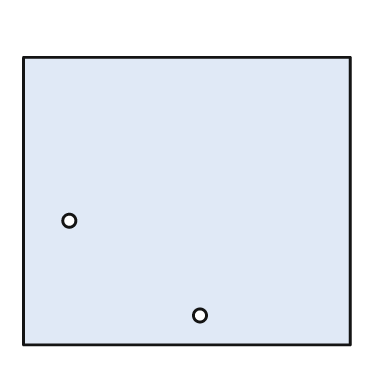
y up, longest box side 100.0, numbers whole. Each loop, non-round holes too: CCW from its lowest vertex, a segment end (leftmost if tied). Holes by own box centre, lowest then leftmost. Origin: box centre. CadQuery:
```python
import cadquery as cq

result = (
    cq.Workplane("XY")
    .moveTo(-50.0, -44.0)
    .lineTo(50.0, -44.0)
    .lineTo(50.0, 44.0)
    .lineTo(-50.0, 44.0)
    .close()
    .moveTo(4.0, -35.0)
    .circle(2.0)
    .moveTo(-36.0, -6.0)
    .circle(2.0)
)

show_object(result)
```